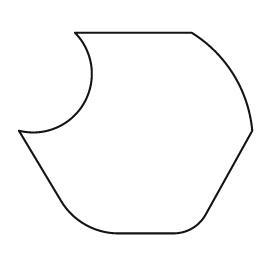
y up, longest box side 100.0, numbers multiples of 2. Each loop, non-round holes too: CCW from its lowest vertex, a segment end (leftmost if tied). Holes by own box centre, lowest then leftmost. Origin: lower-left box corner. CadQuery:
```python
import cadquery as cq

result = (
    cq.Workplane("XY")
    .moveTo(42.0, 0.0)
    .lineTo(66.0, 0.0)
    .threePointArc((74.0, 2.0), (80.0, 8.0))
    .lineTo(100.0, 44.0)
    .threePointArc((92.0, 68.0), (74.0, 86.0))
    .lineTo(24.0, 86.0)
    .threePointArc((28.0, 56.0), (0.0, 44.0))
    .lineTo(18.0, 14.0)
    .threePointArc((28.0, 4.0), (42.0, 0.0))
    .close()
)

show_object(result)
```